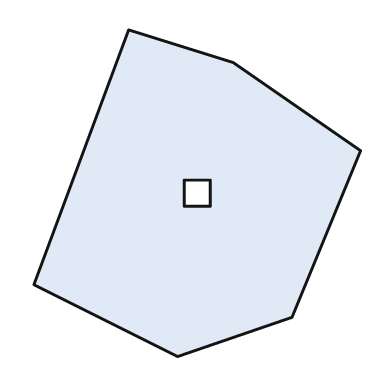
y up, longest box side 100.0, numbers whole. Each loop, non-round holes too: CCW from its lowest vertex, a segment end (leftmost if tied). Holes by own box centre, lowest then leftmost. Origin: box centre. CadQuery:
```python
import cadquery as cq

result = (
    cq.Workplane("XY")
    .moveTo(-6.0, -50.0)
    .lineTo(29.0, -38.0)
    .lineTo(50.0, 13.0)
    .lineTo(11.0, 40.0)
    .lineTo(-21.0, 50.0)
    .lineTo(-50.0, -28.0)
    .close()
    .moveTo(-4.0, -4.0)
    .lineTo(4.0, -4.0)
    .lineTo(4.0, 4.0)
    .lineTo(-4.0, 4.0)
    .close()
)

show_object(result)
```